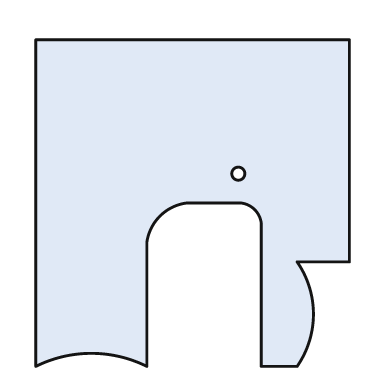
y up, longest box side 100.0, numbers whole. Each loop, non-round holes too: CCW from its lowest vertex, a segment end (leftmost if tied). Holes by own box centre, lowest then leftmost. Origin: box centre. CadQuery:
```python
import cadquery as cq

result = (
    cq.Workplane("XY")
    .moveTo(-48.0, -50.0)
    .threePointArc((-31.0, -46.0), (-14.0, -50.0))
    .lineTo(-14.0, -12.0)
    .threePointArc((-10.0, -4.0), (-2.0, 0.0))
    .lineTo(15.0, 0.0)
    .threePointArc((19.0, -2.0), (21.0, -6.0))
    .lineTo(21.0, -50.0)
    .lineTo(32.0, -50.0)
    .threePointArc((37.0, -34.0), (32.0, -18.0))
    .lineTo(48.0, -18.0)
    .lineTo(48.0, 50.0)
    .lineTo(-48.0, 50.0)
    .close()
    .moveTo(14.0, 9.0)
    .circle(2.0)
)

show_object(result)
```